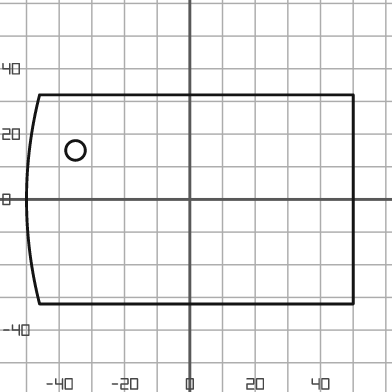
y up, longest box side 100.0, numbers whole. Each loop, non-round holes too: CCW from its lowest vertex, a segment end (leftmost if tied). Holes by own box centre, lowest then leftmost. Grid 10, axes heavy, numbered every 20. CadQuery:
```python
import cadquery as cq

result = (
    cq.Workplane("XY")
    .moveTo(-46.0, -32.0)
    .lineTo(50.0, -32.0)
    .lineTo(50.0, 32.0)
    .lineTo(-46.0, 32.0)
    .threePointArc((-50.0, 0.0), (-46.0, -32.0))
    .close()
    .moveTo(-35.0, 15.0)
    .circle(3.0)
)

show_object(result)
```